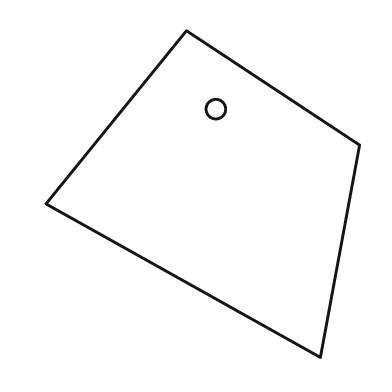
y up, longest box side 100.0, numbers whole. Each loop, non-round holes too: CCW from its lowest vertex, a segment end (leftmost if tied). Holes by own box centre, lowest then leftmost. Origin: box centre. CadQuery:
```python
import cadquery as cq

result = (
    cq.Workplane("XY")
    .moveTo(36.0, -50.0)
    .lineTo(48.0, 15.0)
    .lineTo(-5.0, 50.0)
    .lineTo(-48.0, -3.0)
    .close()
    .moveTo(4.0, 26.0)
    .circle(3.0)
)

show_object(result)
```